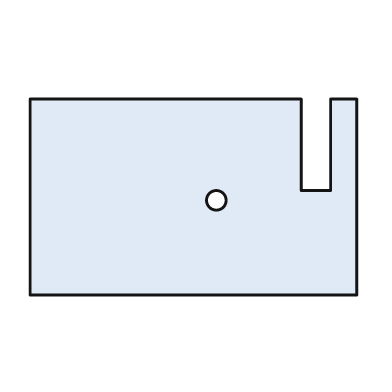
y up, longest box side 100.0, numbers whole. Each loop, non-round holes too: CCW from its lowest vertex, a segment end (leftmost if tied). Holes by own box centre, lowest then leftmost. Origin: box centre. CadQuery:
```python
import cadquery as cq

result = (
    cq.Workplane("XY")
    .moveTo(-50.0, -30.0)
    .lineTo(50.0, -30.0)
    .lineTo(50.0, 30.0)
    .lineTo(42.0, 30.0)
    .lineTo(42.0, 2.0)
    .lineTo(33.0, 2.0)
    .lineTo(33.0, 30.0)
    .lineTo(-50.0, 30.0)
    .close()
    .moveTo(7.0, -1.0)
    .circle(3.0)
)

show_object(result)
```